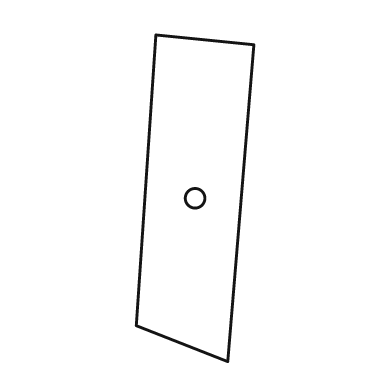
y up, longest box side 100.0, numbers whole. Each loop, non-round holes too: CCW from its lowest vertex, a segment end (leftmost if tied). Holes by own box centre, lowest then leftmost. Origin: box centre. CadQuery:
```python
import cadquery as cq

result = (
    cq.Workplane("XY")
    .moveTo(10.0, -50.0)
    .lineTo(18.0, 47.0)
    .lineTo(-12.0, 50.0)
    .lineTo(-18.0, -39.0)
    .close()
    .moveTo(0.0, 0.0)
    .circle(3.0)
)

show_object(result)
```